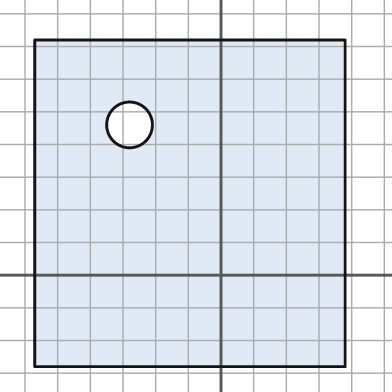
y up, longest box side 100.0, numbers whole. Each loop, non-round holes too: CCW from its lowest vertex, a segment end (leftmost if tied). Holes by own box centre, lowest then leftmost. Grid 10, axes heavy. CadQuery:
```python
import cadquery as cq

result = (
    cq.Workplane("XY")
    .moveTo(-57.0, -28.0)
    .lineTo(38.0, -28.0)
    .lineTo(38.0, 72.0)
    .lineTo(-57.0, 72.0)
    .close()
    .moveTo(-28.0, 46.0)
    .circle(7.0)
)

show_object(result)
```